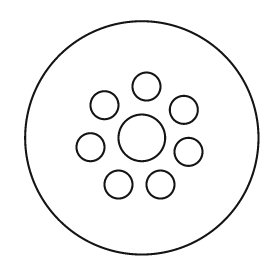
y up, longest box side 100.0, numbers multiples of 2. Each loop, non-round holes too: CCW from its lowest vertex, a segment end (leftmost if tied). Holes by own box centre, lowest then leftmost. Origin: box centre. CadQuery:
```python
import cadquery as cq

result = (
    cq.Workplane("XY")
    .moveTo(0.0, 0.0)
    .circle(50.0)
    .moveTo(-10.0, -20.0)
    .circle(6.0)
    .moveTo(8.0, -20.0)
    .circle(6.0)
    .moveTo(20.0, -6.0)
    .circle(6.0)
    .moveTo(-22.0, -4.0)
    .circle(6.0)
    .moveTo(0.0, 0.0)
    .circle(10.0)
    .moveTo(18.0, 12.0)
    .circle(6.0)
    .moveTo(-16.0, 14.0)
    .circle(6.0)
    .moveTo(2.0, 22.0)
    .circle(6.0)
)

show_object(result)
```